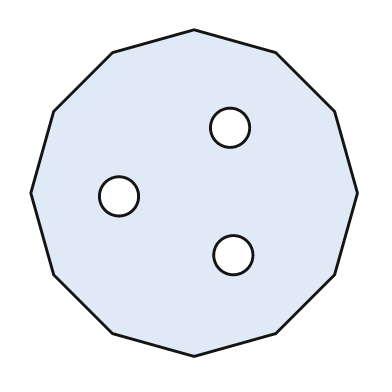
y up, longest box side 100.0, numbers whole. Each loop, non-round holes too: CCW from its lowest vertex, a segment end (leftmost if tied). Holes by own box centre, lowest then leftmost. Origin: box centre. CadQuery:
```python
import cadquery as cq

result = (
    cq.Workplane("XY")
    .moveTo(0.0, -50.0)
    .lineTo(25.0, -43.0)
    .lineTo(43.0, -25.0)
    .lineTo(50.0, 0.0)
    .lineTo(43.0, 25.0)
    .lineTo(25.0, 43.0)
    .lineTo(0.0, 50.0)
    .lineTo(-25.0, 43.0)
    .lineTo(-43.0, 25.0)
    .lineTo(-50.0, 0.0)
    .lineTo(-43.0, -25.0)
    .lineTo(-25.0, -43.0)
    .close()
    .moveTo(12.0, -19.0)
    .circle(6.0)
    .moveTo(-23.0, -1.0)
    .circle(6.0)
    .moveTo(11.0, 20.0)
    .circle(6.0)
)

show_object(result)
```